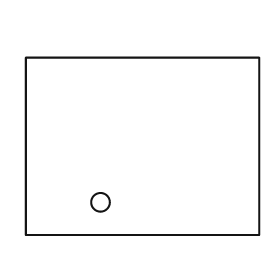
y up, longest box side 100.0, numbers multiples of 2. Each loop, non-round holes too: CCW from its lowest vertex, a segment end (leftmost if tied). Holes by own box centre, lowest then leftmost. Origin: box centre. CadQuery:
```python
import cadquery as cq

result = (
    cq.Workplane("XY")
    .moveTo(-50.0, -38.0)
    .lineTo(50.0, -38.0)
    .lineTo(50.0, 38.0)
    .lineTo(-50.0, 38.0)
    .close()
    .moveTo(-18.0, -24.0)
    .circle(4.0)
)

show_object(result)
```